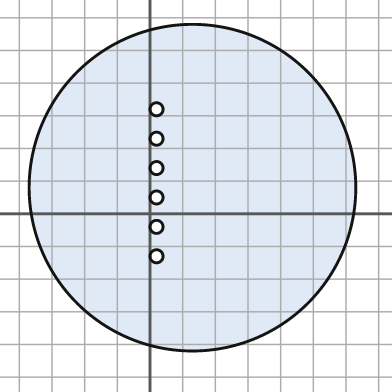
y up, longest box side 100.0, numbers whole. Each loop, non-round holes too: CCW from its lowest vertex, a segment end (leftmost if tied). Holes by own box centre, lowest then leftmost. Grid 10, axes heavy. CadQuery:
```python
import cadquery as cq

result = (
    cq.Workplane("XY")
    .moveTo(13.0, 8.0)
    .circle(50.0)
    .moveTo(2.0, -13.0)
    .circle(2.0)
    .moveTo(2.0, -4.0)
    .circle(2.0)
    .moveTo(2.0, 5.0)
    .circle(2.0)
    .moveTo(2.0, 14.0)
    .circle(2.0)
    .moveTo(2.0, 23.0)
    .circle(2.0)
    .moveTo(2.0, 32.0)
    .circle(2.0)
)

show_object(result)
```